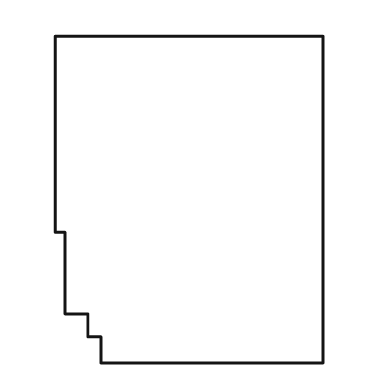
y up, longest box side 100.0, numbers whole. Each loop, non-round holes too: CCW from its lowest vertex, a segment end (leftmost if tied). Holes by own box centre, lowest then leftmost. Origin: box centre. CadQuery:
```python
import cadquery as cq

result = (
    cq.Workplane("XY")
    .moveTo(-27.0, -50.0)
    .lineTo(41.0, -50.0)
    .lineTo(41.0, 50.0)
    .lineTo(-41.0, 50.0)
    .lineTo(-41.0, -10.0)
    .lineTo(-38.0, -10.0)
    .lineTo(-38.0, -35.0)
    .lineTo(-31.0, -35.0)
    .lineTo(-31.0, -42.0)
    .lineTo(-27.0, -42.0)
    .close()
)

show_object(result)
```